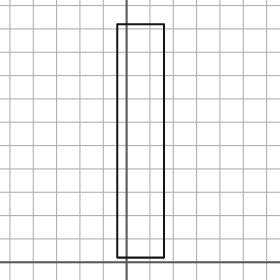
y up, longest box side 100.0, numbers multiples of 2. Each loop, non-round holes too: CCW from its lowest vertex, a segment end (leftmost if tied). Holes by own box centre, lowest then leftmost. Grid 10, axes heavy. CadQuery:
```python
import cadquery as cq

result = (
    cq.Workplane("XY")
    .moveTo(-4.0, 2.0)
    .lineTo(16.0, 2.0)
    .lineTo(16.0, 102.0)
    .lineTo(-4.0, 102.0)
    .close()
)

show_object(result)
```